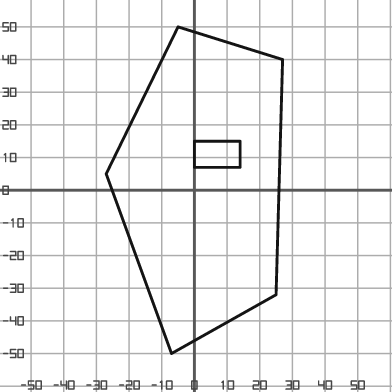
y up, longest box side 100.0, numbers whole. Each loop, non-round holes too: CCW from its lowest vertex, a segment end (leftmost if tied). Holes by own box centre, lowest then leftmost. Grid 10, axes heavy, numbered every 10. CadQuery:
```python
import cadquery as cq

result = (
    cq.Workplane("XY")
    .moveTo(-7.0, -50.0)
    .lineTo(25.0, -32.0)
    .lineTo(27.0, 40.0)
    .lineTo(-5.0, 50.0)
    .lineTo(-27.0, 5.0)
    .close()
    .moveTo(0.0, 7.0)
    .lineTo(14.0, 7.0)
    .lineTo(14.0, 15.0)
    .lineTo(0.0, 15.0)
    .close()
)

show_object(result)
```